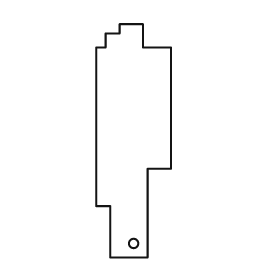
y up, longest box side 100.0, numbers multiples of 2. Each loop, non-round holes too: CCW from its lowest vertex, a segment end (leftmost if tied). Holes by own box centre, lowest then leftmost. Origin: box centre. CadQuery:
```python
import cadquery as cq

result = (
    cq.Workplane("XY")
    .moveTo(-10.0, -50.0)
    .lineTo(6.0, -50.0)
    .lineTo(6.0, -12.0)
    .lineTo(16.0, -12.0)
    .lineTo(16.0, 40.0)
    .lineTo(4.0, 40.0)
    .lineTo(4.0, 50.0)
    .lineTo(-6.0, 50.0)
    .lineTo(-6.0, 46.0)
    .lineTo(-12.0, 46.0)
    .lineTo(-12.0, 40.0)
    .lineTo(-16.0, 40.0)
    .lineTo(-16.0, -28.0)
    .lineTo(-10.0, -28.0)
    .close()
    .moveTo(0.0, -44.0)
    .circle(2.0)
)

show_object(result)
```